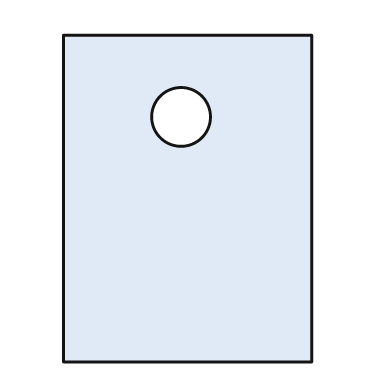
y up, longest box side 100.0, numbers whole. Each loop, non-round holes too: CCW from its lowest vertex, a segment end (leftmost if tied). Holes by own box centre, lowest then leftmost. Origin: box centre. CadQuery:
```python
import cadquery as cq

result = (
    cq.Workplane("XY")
    .moveTo(-38.0, -50.0)
    .lineTo(38.0, -50.0)
    .lineTo(38.0, 50.0)
    .lineTo(-38.0, 50.0)
    .close()
    .moveTo(-2.0, 25.0)
    .circle(9.0)
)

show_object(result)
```